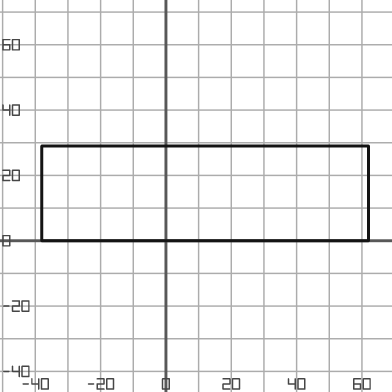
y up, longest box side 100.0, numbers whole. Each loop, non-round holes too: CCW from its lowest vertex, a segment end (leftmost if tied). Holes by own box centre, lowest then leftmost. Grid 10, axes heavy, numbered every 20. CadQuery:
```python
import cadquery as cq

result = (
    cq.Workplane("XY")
    .moveTo(-38.0, 0.0)
    .lineTo(62.0, 0.0)
    .lineTo(62.0, 29.0)
    .lineTo(-38.0, 29.0)
    .close()
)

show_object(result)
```